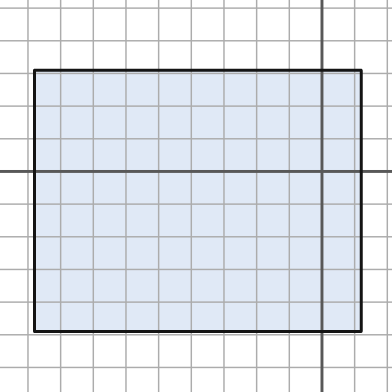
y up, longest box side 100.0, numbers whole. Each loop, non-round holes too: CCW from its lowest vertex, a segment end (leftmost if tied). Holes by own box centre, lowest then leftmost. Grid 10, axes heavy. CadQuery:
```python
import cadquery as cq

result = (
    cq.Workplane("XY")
    .moveTo(-88.0, -49.0)
    .lineTo(12.0, -49.0)
    .lineTo(12.0, 31.0)
    .lineTo(-88.0, 31.0)
    .close()
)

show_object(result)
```